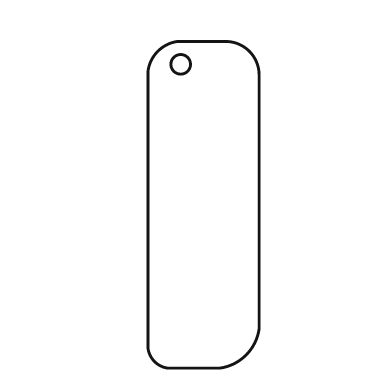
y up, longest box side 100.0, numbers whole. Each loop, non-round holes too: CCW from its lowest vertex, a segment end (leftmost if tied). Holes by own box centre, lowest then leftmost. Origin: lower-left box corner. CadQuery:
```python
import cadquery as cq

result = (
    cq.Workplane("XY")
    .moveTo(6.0, 0.0)
    .lineTo(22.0, 0.0)
    .threePointArc((30.0, 4.0), (34.0, 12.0))
    .lineTo(34.0, 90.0)
    .threePointArc((31.0, 97.0), (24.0, 100.0))
    .lineTo(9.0, 100.0)
    .threePointArc((3.0, 97.0), (0.0, 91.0))
    .lineTo(0.0, 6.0)
    .threePointArc((2.0, 2.0), (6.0, 0.0))
    .close()
    .moveTo(10.0, 93.0)
    .circle(3.0)
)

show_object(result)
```